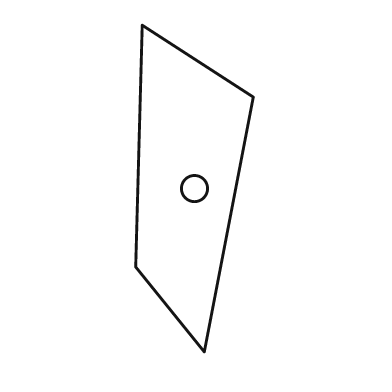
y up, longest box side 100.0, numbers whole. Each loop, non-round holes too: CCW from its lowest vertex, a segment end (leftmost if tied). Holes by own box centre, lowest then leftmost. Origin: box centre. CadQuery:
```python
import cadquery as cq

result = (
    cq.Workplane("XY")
    .moveTo(3.0, -50.0)
    .lineTo(18.0, 28.0)
    .lineTo(-16.0, 50.0)
    .lineTo(-18.0, -24.0)
    .close()
    .moveTo(0.0, 0.0)
    .circle(4.0)
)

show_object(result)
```